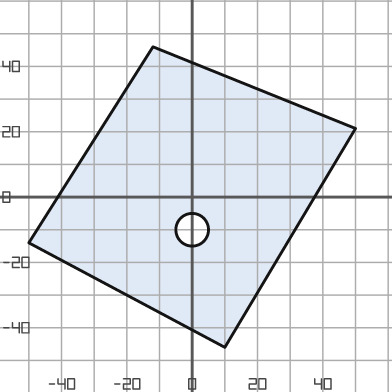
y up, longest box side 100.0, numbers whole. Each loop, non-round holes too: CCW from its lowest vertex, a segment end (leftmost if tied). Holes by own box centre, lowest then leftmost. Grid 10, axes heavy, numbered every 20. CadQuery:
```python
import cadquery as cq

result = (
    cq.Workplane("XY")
    .moveTo(10.0, -46.0)
    .lineTo(50.0, 21.0)
    .lineTo(-12.0, 46.0)
    .lineTo(-50.0, -14.0)
    .close()
    .moveTo(0.0, -10.0)
    .circle(5.0)
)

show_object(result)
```